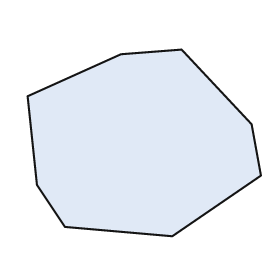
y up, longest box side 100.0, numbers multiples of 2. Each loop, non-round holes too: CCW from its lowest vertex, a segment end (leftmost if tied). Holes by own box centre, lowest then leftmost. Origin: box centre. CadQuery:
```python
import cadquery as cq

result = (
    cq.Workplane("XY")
    .moveTo(12.0, -40.0)
    .lineTo(50.0, -14.0)
    .lineTo(46.0, 8.0)
    .lineTo(16.0, 40.0)
    .lineTo(-10.0, 38.0)
    .lineTo(-50.0, 20.0)
    .lineTo(-46.0, -18.0)
    .lineTo(-34.0, -36.0)
    .close()
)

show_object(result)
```